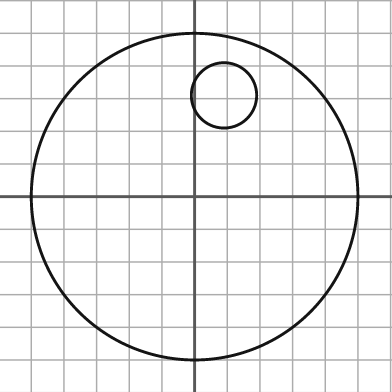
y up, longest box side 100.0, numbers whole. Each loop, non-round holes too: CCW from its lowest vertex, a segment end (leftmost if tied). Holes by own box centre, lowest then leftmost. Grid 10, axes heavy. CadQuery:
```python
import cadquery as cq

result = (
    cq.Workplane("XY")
    .moveTo(0.0, 0.0)
    .circle(50.0)
    .moveTo(9.0, 31.0)
    .circle(10.0)
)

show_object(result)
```